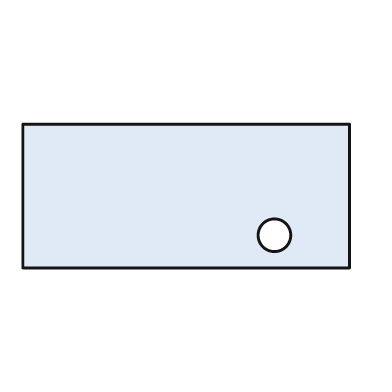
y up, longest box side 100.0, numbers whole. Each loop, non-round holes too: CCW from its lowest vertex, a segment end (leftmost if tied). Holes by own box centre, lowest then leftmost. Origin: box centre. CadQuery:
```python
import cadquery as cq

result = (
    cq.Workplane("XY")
    .moveTo(-50.0, -22.0)
    .lineTo(50.0, -22.0)
    .lineTo(50.0, 22.0)
    .lineTo(-50.0, 22.0)
    .close()
    .moveTo(27.0, -12.0)
    .circle(5.0)
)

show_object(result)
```